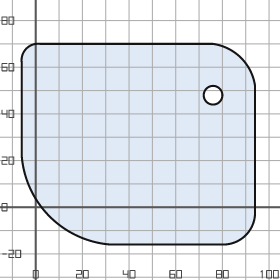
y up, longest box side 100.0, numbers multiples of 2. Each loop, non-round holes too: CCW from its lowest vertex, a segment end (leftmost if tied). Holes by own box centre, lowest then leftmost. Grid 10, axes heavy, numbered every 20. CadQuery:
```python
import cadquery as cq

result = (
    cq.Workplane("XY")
    .moveTo(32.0, -16.0)
    .lineTo(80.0, -16.0)
    .threePointArc((90.0, -12.0), (94.0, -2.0))
    .lineTo(94.0, 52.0)
    .threePointArc((88.0, 64.0), (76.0, 70.0))
    .lineTo(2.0, 70.0)
    .threePointArc((-4.0, 68.0), (-6.0, 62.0))
    .lineTo(-6.0, 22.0)
    .threePointArc((6.0, -4.0), (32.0, -16.0))
    .close()
    .moveTo(76.0, 48.0)
    .circle(4.0)
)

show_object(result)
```